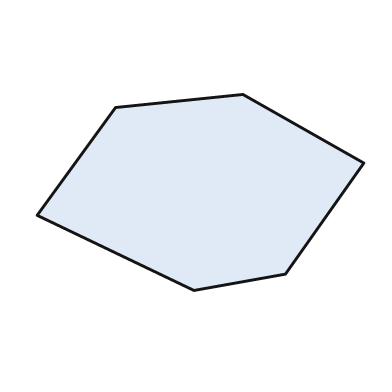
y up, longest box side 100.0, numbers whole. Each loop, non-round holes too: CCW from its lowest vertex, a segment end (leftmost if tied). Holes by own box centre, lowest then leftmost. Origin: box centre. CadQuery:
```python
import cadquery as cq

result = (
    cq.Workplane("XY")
    .moveTo(-2.0, -30.0)
    .lineTo(26.0, -25.0)
    .lineTo(50.0, 9.0)
    .lineTo(13.0, 30.0)
    .lineTo(-26.0, 26.0)
    .lineTo(-50.0, -7.0)
    .close()
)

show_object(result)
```